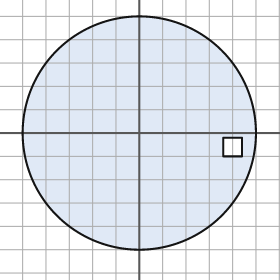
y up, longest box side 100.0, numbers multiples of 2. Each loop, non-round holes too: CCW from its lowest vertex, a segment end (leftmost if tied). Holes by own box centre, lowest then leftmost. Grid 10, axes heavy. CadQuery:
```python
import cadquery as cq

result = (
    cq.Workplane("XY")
    .moveTo(0.0, 0.0)
    .circle(50.0)
    .moveTo(36.0, -10.0)
    .lineTo(44.0, -10.0)
    .lineTo(44.0, -2.0)
    .lineTo(36.0, -2.0)
    .close()
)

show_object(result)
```